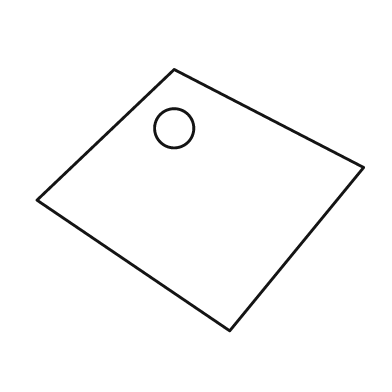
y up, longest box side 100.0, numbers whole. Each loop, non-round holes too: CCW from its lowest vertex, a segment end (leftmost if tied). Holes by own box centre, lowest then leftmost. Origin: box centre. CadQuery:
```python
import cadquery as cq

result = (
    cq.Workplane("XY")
    .moveTo(9.0, -40.0)
    .lineTo(50.0, 10.0)
    .lineTo(-8.0, 40.0)
    .lineTo(-50.0, 0.0)
    .close()
    .moveTo(-8.0, 22.0)
    .circle(6.0)
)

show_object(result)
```